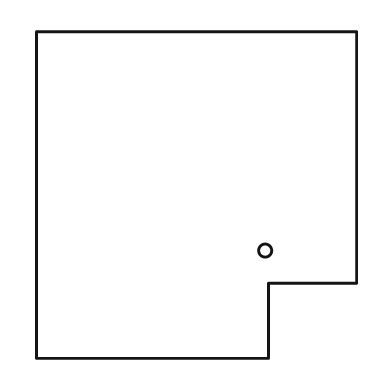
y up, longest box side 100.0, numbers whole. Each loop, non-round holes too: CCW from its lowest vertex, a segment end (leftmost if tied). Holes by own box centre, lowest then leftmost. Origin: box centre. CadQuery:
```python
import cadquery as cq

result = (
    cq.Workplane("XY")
    .moveTo(-49.0, -50.0)
    .lineTo(22.0, -50.0)
    .lineTo(22.0, -27.0)
    .lineTo(49.0, -27.0)
    .lineTo(49.0, 50.0)
    .lineTo(-49.0, 50.0)
    .close()
    .moveTo(21.0, -17.0)
    .circle(2.0)
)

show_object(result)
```